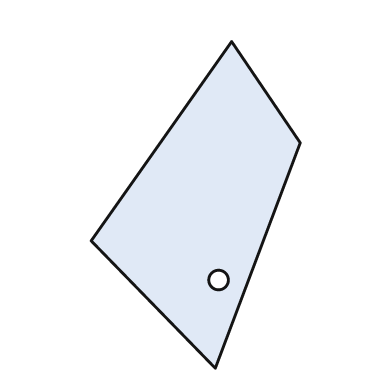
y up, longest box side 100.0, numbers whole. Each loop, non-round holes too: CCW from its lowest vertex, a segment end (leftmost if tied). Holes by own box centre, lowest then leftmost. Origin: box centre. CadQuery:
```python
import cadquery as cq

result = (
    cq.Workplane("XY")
    .moveTo(6.0, -50.0)
    .lineTo(32.0, 19.0)
    .lineTo(11.0, 50.0)
    .lineTo(-32.0, -11.0)
    .close()
    .moveTo(7.0, -23.0)
    .circle(3.0)
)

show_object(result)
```